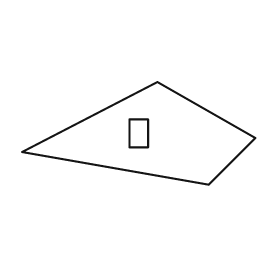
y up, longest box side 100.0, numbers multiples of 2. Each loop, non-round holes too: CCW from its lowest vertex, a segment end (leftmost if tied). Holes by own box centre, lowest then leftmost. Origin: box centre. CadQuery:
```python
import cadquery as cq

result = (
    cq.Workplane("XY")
    .moveTo(30.0, -22.0)
    .lineTo(50.0, -2.0)
    .lineTo(8.0, 22.0)
    .lineTo(-50.0, -8.0)
    .close()
    .moveTo(-4.0, -6.0)
    .lineTo(4.0, -6.0)
    .lineTo(4.0, 6.0)
    .lineTo(-4.0, 6.0)
    .close()
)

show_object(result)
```